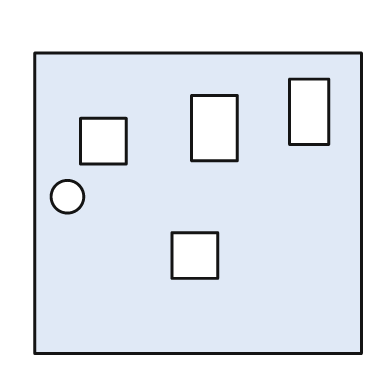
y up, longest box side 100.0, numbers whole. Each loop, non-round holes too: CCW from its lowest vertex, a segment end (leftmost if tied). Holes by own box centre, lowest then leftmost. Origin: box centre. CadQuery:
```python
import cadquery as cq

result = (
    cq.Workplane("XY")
    .moveTo(-50.0, -46.0)
    .lineTo(50.0, -46.0)
    .lineTo(50.0, 46.0)
    .lineTo(-50.0, 46.0)
    .close()
    .moveTo(-8.0, -23.0)
    .lineTo(6.0, -23.0)
    .lineTo(6.0, -9.0)
    .lineTo(-8.0, -9.0)
    .close()
    .moveTo(-40.0, 2.0)
    .circle(5.0)
    .moveTo(-36.0, 12.0)
    .lineTo(-22.0, 12.0)
    .lineTo(-22.0, 26.0)
    .lineTo(-36.0, 26.0)
    .close()
    .moveTo(-2.0, 13.0)
    .lineTo(12.0, 13.0)
    .lineTo(12.0, 33.0)
    .lineTo(-2.0, 33.0)
    .close()
    .moveTo(28.0, 18.0)
    .lineTo(40.0, 18.0)
    .lineTo(40.0, 38.0)
    .lineTo(28.0, 38.0)
    .close()
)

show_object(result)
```